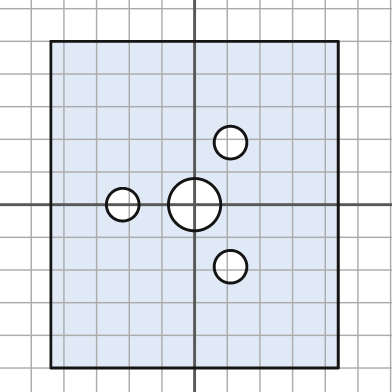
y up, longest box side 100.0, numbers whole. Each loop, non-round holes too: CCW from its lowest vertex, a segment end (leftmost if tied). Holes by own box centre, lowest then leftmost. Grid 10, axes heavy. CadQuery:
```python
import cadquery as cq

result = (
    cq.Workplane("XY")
    .moveTo(-44.0, -50.0)
    .lineTo(44.0, -50.0)
    .lineTo(44.0, 50.0)
    .lineTo(-44.0, 50.0)
    .close()
    .moveTo(11.0, -19.0)
    .circle(5.0)
    .moveTo(-22.0, 0.0)
    .circle(5.0)
    .moveTo(0.0, 0.0)
    .circle(8.0)
    .moveTo(11.0, 19.0)
    .circle(5.0)
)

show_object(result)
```